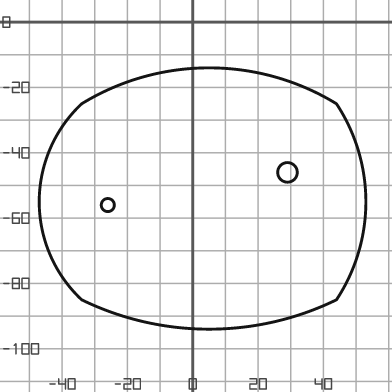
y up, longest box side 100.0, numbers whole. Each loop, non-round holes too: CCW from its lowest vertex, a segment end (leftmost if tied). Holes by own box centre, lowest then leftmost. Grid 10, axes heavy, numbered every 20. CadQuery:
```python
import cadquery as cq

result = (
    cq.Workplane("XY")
    .moveTo(-34.0, -85.0)
    .threePointArc((5.0, -94.0), (44.0, -85.0))
    .threePointArc((53.0, -55.0), (44.0, -25.0))
    .threePointArc((5.0, -14.0), (-34.0, -25.0))
    .threePointArc((-47.0, -55.0), (-34.0, -85.0))
    .close()
    .moveTo(-26.0, -56.0)
    .circle(2.0)
    .moveTo(29.0, -46.0)
    .circle(3.0)
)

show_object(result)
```